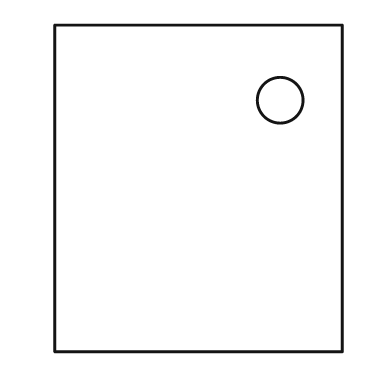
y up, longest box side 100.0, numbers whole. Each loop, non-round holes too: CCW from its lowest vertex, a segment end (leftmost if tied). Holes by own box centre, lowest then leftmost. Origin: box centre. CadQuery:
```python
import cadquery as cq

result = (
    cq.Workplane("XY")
    .moveTo(-44.0, -50.0)
    .lineTo(44.0, -50.0)
    .lineTo(44.0, 50.0)
    .lineTo(-44.0, 50.0)
    .close()
    .moveTo(25.0, 27.0)
    .circle(7.0)
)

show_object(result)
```